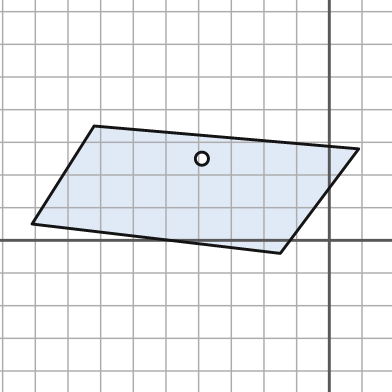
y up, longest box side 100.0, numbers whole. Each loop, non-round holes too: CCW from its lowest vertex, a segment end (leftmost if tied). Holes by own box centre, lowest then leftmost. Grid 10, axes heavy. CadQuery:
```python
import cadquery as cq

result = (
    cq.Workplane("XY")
    .moveTo(-15.0, -4.0)
    .lineTo(9.0, 28.0)
    .lineTo(-72.0, 35.0)
    .lineTo(-91.0, 5.0)
    .close()
    .moveTo(-39.0, 25.0)
    .circle(2.0)
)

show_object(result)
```